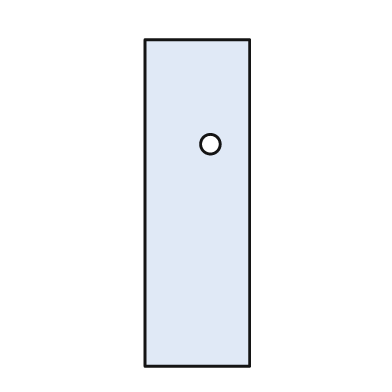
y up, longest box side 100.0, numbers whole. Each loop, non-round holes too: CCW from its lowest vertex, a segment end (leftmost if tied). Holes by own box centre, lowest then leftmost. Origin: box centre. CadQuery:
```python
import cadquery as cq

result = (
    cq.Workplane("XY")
    .moveTo(-16.0, -50.0)
    .lineTo(16.0, -50.0)
    .lineTo(16.0, 50.0)
    .lineTo(-16.0, 50.0)
    .close()
    .moveTo(4.0, 18.0)
    .circle(3.0)
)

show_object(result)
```